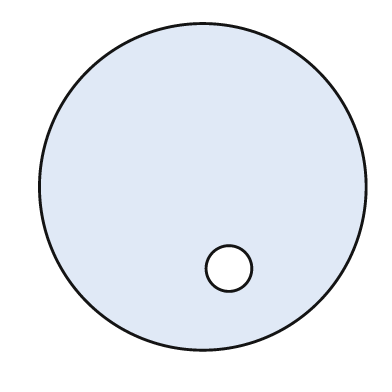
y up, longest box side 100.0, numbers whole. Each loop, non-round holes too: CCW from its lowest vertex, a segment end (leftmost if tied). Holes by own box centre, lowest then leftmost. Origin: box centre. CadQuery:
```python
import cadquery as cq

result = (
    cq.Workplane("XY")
    .moveTo(0.0, 0.0)
    .circle(50.0)
    .moveTo(8.0, -25.0)
    .circle(7.0)
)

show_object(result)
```